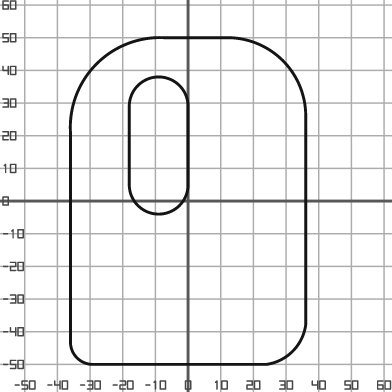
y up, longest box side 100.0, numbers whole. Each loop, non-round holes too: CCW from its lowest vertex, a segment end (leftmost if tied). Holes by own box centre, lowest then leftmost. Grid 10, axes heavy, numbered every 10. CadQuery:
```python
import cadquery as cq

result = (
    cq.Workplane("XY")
    .moveTo(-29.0, -50.0)
    .lineTo(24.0, -50.0)
    .threePointArc((32.0, -46.0), (36.0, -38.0))
    .lineTo(36.0, 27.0)
    .threePointArc((29.0, 43.0), (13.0, 50.0))
    .lineTo(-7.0, 50.0)
    .threePointArc((-28.0, 42.0), (-36.0, 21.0))
    .lineTo(-36.0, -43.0)
    .threePointArc((-34.0, -48.0), (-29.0, -50.0))
    .close()
    .moveTo(-18.0, 5.0)
    .threePointArc((-9.0, -4.0), (0.0, 5.0))
    .lineTo(0.0, 29.0)
    .threePointArc((-9.0, 38.0), (-18.0, 29.0))
    .close()
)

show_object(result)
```